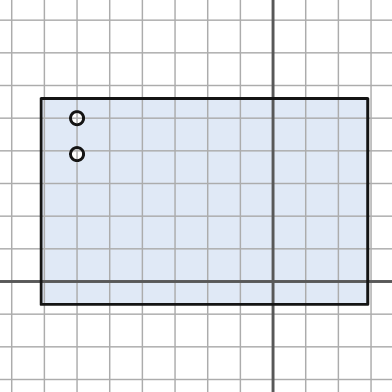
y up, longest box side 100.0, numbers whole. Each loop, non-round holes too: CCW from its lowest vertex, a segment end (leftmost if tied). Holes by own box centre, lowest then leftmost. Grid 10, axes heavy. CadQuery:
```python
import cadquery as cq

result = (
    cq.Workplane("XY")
    .moveTo(-71.0, -7.0)
    .lineTo(29.0, -7.0)
    .lineTo(29.0, 56.0)
    .lineTo(-71.0, 56.0)
    .close()
    .moveTo(-60.0, 39.0)
    .circle(2.0)
    .moveTo(-60.0, 50.0)
    .circle(2.0)
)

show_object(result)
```